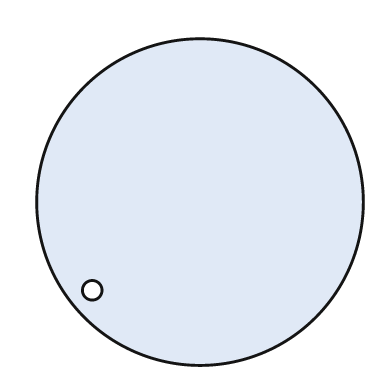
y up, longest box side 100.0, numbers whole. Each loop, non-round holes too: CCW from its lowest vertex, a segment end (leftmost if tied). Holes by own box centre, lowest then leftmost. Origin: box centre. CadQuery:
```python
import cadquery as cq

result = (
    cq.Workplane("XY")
    .moveTo(0.0, 0.0)
    .circle(50.0)
    .moveTo(-33.0, -27.0)
    .circle(3.0)
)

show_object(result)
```